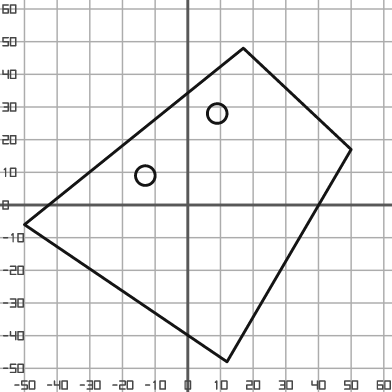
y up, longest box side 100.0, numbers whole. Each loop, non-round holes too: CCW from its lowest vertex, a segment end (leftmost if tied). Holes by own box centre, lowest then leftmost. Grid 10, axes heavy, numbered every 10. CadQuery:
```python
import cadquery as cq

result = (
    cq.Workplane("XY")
    .moveTo(12.0, -48.0)
    .lineTo(50.0, 17.0)
    .lineTo(17.0, 48.0)
    .lineTo(-50.0, -6.0)
    .close()
    .moveTo(-13.0, 9.0)
    .circle(3.0)
    .moveTo(9.0, 28.0)
    .circle(3.0)
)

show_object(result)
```